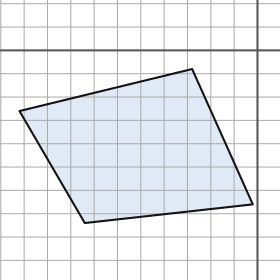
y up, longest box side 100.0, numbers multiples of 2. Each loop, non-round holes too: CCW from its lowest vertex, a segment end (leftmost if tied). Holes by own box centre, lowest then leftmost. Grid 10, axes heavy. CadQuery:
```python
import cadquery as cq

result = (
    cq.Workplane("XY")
    .moveTo(-74.0, -74.0)
    .lineTo(-2.0, -66.0)
    .lineTo(-28.0, -8.0)
    .lineTo(-102.0, -26.0)
    .close()
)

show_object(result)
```